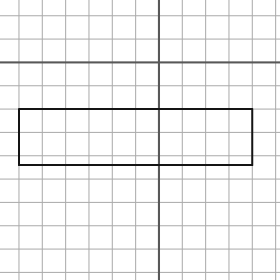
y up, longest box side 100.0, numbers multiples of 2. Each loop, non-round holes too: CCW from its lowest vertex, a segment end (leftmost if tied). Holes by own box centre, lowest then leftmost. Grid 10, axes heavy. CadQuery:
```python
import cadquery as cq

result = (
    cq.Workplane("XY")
    .moveTo(-60.0, -44.0)
    .lineTo(40.0, -44.0)
    .lineTo(40.0, -20.0)
    .lineTo(-60.0, -20.0)
    .close()
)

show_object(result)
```